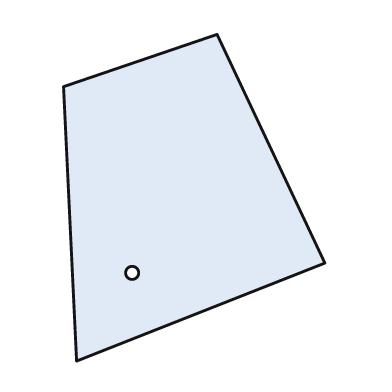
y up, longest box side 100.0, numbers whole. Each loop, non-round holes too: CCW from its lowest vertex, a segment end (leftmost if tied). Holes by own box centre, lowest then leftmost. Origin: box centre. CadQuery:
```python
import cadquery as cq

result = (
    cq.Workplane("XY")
    .moveTo(-36.0, -50.0)
    .lineTo(40.0, -20.0)
    .lineTo(7.0, 50.0)
    .lineTo(-40.0, 34.0)
    .close()
    .moveTo(-19.0, -23.0)
    .circle(2.0)
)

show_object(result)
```